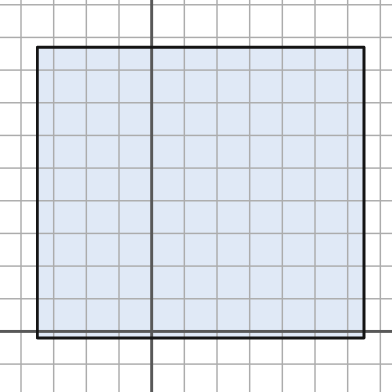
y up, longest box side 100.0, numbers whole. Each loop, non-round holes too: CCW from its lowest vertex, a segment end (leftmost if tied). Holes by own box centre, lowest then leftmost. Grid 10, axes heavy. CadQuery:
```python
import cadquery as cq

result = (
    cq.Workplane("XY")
    .moveTo(-35.0, -2.0)
    .lineTo(65.0, -2.0)
    .lineTo(65.0, 87.0)
    .lineTo(-35.0, 87.0)
    .close()
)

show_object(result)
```